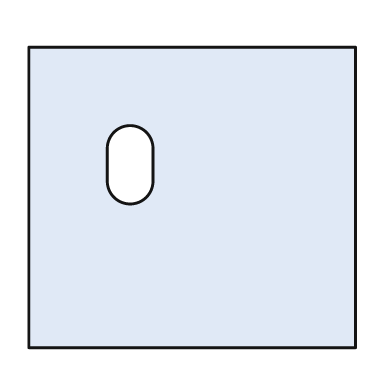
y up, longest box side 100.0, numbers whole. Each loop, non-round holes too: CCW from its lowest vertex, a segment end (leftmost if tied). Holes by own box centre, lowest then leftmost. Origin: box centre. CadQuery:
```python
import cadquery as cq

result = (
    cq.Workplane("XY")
    .moveTo(-50.0, -46.0)
    .lineTo(50.0, -46.0)
    .lineTo(50.0, 46.0)
    .lineTo(-50.0, 46.0)
    .close()
    .moveTo(-26.0, 5.0)
    .threePointArc((-19.0, -2.0), (-12.0, 5.0))
    .lineTo(-12.0, 15.0)
    .threePointArc((-19.0, 22.0), (-26.0, 15.0))
    .close()
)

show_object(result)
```